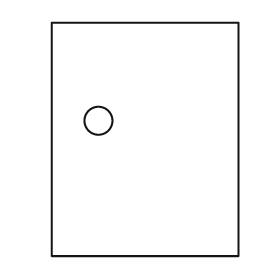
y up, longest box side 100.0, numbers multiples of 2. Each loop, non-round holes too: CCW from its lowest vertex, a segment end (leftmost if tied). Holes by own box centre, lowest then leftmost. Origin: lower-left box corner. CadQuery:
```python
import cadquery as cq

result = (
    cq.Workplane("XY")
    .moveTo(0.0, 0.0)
    .lineTo(80.0, 0.0)
    .lineTo(80.0, 100.0)
    .lineTo(0.0, 100.0)
    .close()
    .moveTo(20.0, 58.0)
    .circle(6.0)
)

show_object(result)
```